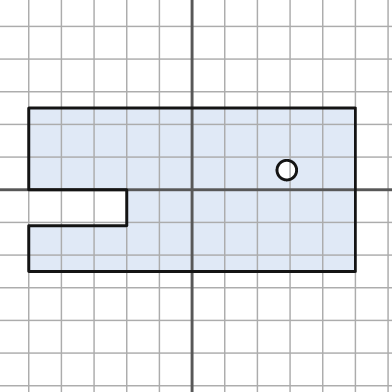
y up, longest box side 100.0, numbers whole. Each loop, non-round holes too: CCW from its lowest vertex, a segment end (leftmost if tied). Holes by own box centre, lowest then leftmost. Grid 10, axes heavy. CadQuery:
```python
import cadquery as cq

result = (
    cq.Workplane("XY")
    .moveTo(-50.0, -25.0)
    .lineTo(50.0, -25.0)
    .lineTo(50.0, 25.0)
    .lineTo(-50.0, 25.0)
    .lineTo(-50.0, 0.0)
    .lineTo(-20.0, 0.0)
    .lineTo(-20.0, -11.0)
    .lineTo(-50.0, -11.0)
    .close()
    .moveTo(29.0, 6.0)
    .circle(3.0)
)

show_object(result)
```